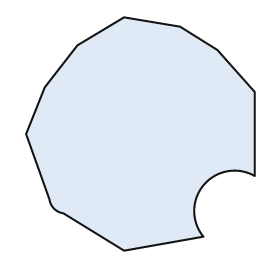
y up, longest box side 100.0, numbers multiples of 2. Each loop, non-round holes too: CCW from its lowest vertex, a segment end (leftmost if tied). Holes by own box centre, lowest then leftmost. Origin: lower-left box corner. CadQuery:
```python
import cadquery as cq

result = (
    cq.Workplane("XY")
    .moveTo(42.0, 0.0)
    .lineTo(76.0, 6.0)
    .threePointArc((76.0, 28.0), (98.0, 32.0))
    .lineTo(98.0, 68.0)
    .lineTo(82.0, 86.0)
    .lineTo(66.0, 96.0)
    .lineTo(42.0, 100.0)
    .lineTo(22.0, 88.0)
    .lineTo(8.0, 70.0)
    .lineTo(0.0, 50.0)
    .lineTo(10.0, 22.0)
    .threePointArc((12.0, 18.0), (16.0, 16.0))
    .close()
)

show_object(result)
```